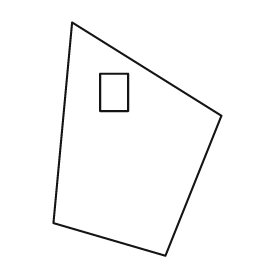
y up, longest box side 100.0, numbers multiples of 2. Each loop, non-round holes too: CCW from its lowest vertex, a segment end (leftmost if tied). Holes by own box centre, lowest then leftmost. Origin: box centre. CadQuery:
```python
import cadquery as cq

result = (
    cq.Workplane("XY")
    .moveTo(12.0, -50.0)
    .lineTo(36.0, 10.0)
    .lineTo(-28.0, 50.0)
    .lineTo(-36.0, -36.0)
    .close()
    .moveTo(-16.0, 12.0)
    .lineTo(-4.0, 12.0)
    .lineTo(-4.0, 28.0)
    .lineTo(-16.0, 28.0)
    .close()
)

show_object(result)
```